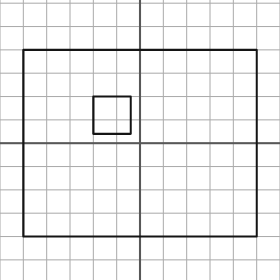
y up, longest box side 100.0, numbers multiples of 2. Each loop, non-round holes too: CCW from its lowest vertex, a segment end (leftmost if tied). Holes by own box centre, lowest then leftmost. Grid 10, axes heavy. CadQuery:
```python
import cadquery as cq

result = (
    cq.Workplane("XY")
    .moveTo(-50.0, -40.0)
    .lineTo(50.0, -40.0)
    .lineTo(50.0, 40.0)
    .lineTo(-50.0, 40.0)
    .close()
    .moveTo(-20.0, 4.0)
    .lineTo(-4.0, 4.0)
    .lineTo(-4.0, 20.0)
    .lineTo(-20.0, 20.0)
    .close()
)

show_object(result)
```